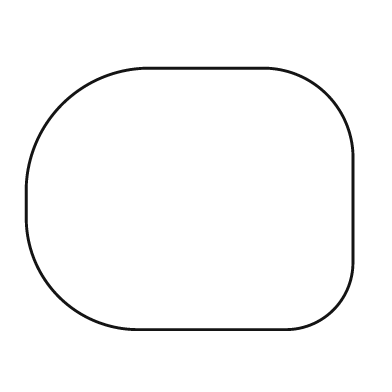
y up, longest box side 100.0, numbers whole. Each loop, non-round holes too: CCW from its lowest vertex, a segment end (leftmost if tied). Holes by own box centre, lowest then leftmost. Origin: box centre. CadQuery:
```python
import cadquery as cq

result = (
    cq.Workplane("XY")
    .moveTo(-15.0, -40.0)
    .lineTo(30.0, -40.0)
    .threePointArc((44.0, -34.0), (50.0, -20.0))
    .lineTo(50.0, 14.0)
    .threePointArc((42.0, 32.0), (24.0, 40.0))
    .lineTo(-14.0, 40.0)
    .threePointArc((-39.0, 29.0), (-50.0, 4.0))
    .lineTo(-50.0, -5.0)
    .threePointArc((-40.0, -30.0), (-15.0, -40.0))
    .close()
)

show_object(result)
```